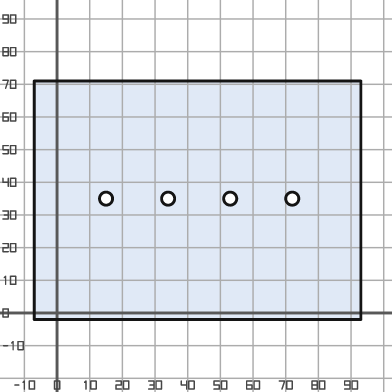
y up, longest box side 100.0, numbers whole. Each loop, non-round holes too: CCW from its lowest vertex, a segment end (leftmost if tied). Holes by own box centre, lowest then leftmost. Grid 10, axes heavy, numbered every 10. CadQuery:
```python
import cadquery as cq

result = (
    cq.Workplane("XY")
    .moveTo(-7.0, -2.0)
    .lineTo(93.0, -2.0)
    .lineTo(93.0, 71.0)
    .lineTo(-7.0, 71.0)
    .close()
    .moveTo(15.0, 35.0)
    .circle(2.0)
    .moveTo(34.0, 35.0)
    .circle(2.0)
    .moveTo(53.0, 35.0)
    .circle(2.0)
    .moveTo(72.0, 35.0)
    .circle(2.0)
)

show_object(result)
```